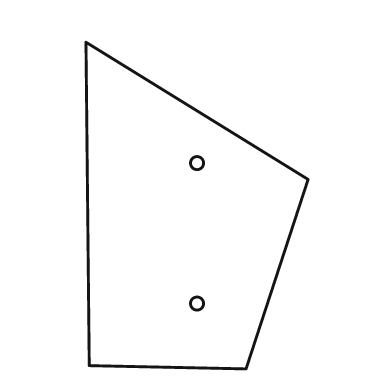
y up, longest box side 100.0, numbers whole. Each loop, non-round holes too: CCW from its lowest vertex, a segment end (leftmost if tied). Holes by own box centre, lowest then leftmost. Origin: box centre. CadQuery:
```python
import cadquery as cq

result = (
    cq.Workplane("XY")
    .moveTo(15.0, -50.0)
    .lineTo(34.0, 8.0)
    .lineTo(-34.0, 50.0)
    .lineTo(-33.0, -49.0)
    .close()
    .moveTo(0.0, -30.0)
    .circle(2.0)
    .moveTo(0.0, 13.0)
    .circle(2.0)
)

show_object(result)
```